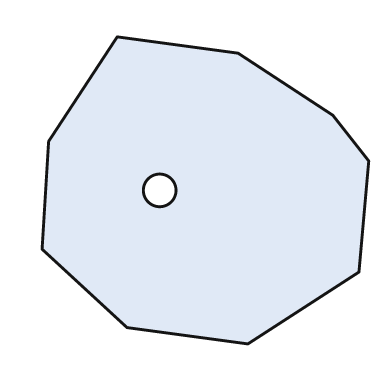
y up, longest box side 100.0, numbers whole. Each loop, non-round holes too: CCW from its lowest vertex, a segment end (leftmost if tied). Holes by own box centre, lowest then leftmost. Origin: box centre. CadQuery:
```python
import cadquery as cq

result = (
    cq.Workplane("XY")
    .moveTo(13.0, -47.0)
    .lineTo(47.0, -25.0)
    .lineTo(50.0, 9.0)
    .lineTo(39.0, 23.0)
    .lineTo(10.0, 42.0)
    .lineTo(-27.0, 47.0)
    .lineTo(-48.0, 15.0)
    .lineTo(-50.0, -18.0)
    .lineTo(-24.0, -42.0)
    .close()
    .moveTo(-14.0, 0.0)
    .circle(5.0)
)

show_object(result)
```